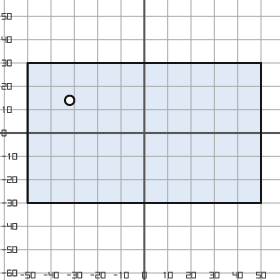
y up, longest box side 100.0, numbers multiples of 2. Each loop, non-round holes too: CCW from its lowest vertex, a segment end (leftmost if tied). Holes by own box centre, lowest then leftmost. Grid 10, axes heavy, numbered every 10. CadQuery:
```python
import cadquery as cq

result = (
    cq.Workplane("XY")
    .moveTo(-50.0, -30.0)
    .lineTo(50.0, -30.0)
    .lineTo(50.0, 30.0)
    .lineTo(-50.0, 30.0)
    .close()
    .moveTo(-32.0, 14.0)
    .circle(2.0)
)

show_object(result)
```